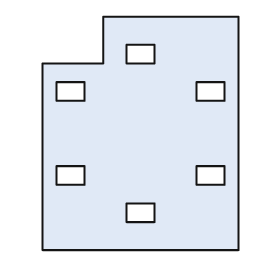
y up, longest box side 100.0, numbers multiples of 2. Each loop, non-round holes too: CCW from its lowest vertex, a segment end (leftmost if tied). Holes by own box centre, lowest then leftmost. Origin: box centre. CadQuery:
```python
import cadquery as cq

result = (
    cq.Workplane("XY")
    .moveTo(-42.0, -50.0)
    .lineTo(42.0, -50.0)
    .lineTo(42.0, 50.0)
    .lineTo(-16.0, 50.0)
    .lineTo(-16.0, 30.0)
    .lineTo(-42.0, 30.0)
    .close()
    .moveTo(-6.0, -38.0)
    .lineTo(6.0, -38.0)
    .lineTo(6.0, -30.0)
    .lineTo(-6.0, -30.0)
    .close()
    .moveTo(-36.0, -22.0)
    .lineTo(-24.0, -22.0)
    .lineTo(-24.0, -14.0)
    .lineTo(-36.0, -14.0)
    .close()
    .moveTo(24.0, -22.0)
    .lineTo(36.0, -22.0)
    .lineTo(36.0, -14.0)
    .lineTo(24.0, -14.0)
    .close()
    .moveTo(-36.0, 14.0)
    .lineTo(-24.0, 14.0)
    .lineTo(-24.0, 22.0)
    .lineTo(-36.0, 22.0)
    .close()
    .moveTo(24.0, 14.0)
    .lineTo(36.0, 14.0)
    .lineTo(36.0, 22.0)
    .lineTo(24.0, 22.0)
    .close()
    .moveTo(-6.0, 30.0)
    .lineTo(6.0, 30.0)
    .lineTo(6.0, 38.0)
    .lineTo(-6.0, 38.0)
    .close()
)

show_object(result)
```